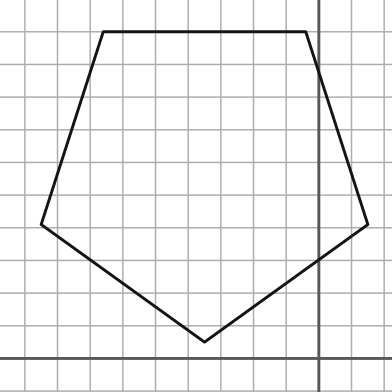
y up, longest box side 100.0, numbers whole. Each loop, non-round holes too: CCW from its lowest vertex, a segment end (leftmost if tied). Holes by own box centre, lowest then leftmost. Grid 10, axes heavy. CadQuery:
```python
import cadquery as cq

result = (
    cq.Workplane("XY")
    .moveTo(-35.0, 5.0)
    .lineTo(15.0, 41.0)
    .lineTo(-4.0, 100.0)
    .lineTo(-66.0, 100.0)
    .lineTo(-85.0, 41.0)
    .close()
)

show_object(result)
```